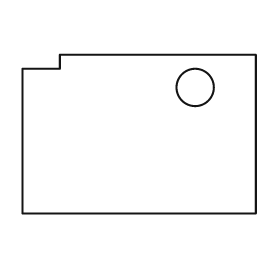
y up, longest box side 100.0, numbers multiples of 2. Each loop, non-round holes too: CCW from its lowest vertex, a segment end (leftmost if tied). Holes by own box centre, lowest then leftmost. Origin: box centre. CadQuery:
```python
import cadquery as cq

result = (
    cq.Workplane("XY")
    .moveTo(-50.0, -34.0)
    .lineTo(50.0, -34.0)
    .lineTo(50.0, 34.0)
    .lineTo(-34.0, 34.0)
    .lineTo(-34.0, 28.0)
    .lineTo(-50.0, 28.0)
    .close()
    .moveTo(24.0, 20.0)
    .circle(8.0)
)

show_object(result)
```